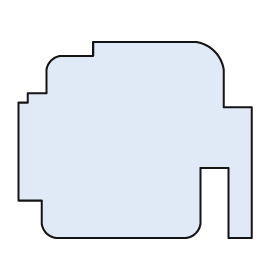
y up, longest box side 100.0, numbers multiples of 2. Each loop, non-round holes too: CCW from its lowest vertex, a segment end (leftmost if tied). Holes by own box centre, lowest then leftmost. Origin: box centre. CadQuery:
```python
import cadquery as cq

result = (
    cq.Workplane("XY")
    .moveTo(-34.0, -42.0)
    .lineTo(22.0, -42.0)
    .threePointArc((26.0, -40.0), (28.0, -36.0))
    .lineTo(28.0, -12.0)
    .lineTo(40.0, -12.0)
    .lineTo(40.0, -42.0)
    .lineTo(50.0, -42.0)
    .lineTo(50.0, 14.0)
    .lineTo(38.0, 14.0)
    .lineTo(38.0, 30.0)
    .threePointArc((34.0, 38.0), (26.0, 42.0))
    .lineTo(-18.0, 42.0)
    .lineTo(-18.0, 36.0)
    .lineTo(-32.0, 36.0)
    .threePointArc((-36.0, 34.0), (-38.0, 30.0))
    .lineTo(-38.0, 20.0)
    .lineTo(-46.0, 20.0)
    .lineTo(-46.0, 16.0)
    .lineTo(-50.0, 16.0)
    .lineTo(-50.0, -26.0)
    .lineTo(-40.0, -26.0)
    .lineTo(-40.0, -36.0)
    .threePointArc((-38.0, -40.0), (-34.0, -42.0))
    .close()
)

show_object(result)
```